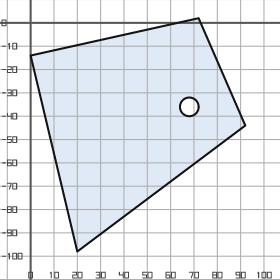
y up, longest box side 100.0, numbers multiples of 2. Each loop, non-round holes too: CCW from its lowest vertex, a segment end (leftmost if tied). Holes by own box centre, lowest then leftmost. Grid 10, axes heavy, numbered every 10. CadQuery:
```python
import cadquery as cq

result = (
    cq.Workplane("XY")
    .moveTo(20.0, -98.0)
    .lineTo(92.0, -44.0)
    .lineTo(72.0, 2.0)
    .lineTo(0.0, -14.0)
    .close()
    .moveTo(68.0, -36.0)
    .circle(4.0)
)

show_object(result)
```